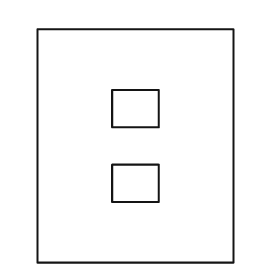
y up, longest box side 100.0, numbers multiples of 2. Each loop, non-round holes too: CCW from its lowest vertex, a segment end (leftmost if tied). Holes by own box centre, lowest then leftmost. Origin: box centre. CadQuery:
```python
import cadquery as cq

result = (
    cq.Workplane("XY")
    .moveTo(-42.0, -50.0)
    .lineTo(42.0, -50.0)
    .lineTo(42.0, 50.0)
    .lineTo(-42.0, 50.0)
    .close()
    .moveTo(-10.0, -24.0)
    .lineTo(10.0, -24.0)
    .lineTo(10.0, -8.0)
    .lineTo(-10.0, -8.0)
    .close()
    .moveTo(-10.0, 8.0)
    .lineTo(10.0, 8.0)
    .lineTo(10.0, 24.0)
    .lineTo(-10.0, 24.0)
    .close()
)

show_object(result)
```